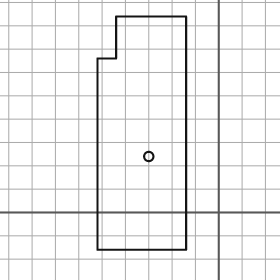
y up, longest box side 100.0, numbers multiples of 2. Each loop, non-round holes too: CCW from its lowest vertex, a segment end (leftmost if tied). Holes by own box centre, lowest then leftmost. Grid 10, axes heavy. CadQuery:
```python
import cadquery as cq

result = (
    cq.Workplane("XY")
    .moveTo(-52.0, -16.0)
    .lineTo(-14.0, -16.0)
    .lineTo(-14.0, 84.0)
    .lineTo(-44.0, 84.0)
    .lineTo(-44.0, 66.0)
    .lineTo(-52.0, 66.0)
    .close()
    .moveTo(-30.0, 24.0)
    .circle(2.0)
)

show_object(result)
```